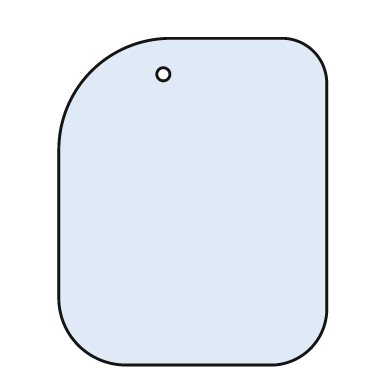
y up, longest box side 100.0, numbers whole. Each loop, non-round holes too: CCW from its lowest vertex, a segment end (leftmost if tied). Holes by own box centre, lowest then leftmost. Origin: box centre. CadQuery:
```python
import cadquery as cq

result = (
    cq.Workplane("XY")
    .moveTo(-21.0, -50.0)
    .lineTo(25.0, -50.0)
    .threePointArc((36.0, -45.0), (41.0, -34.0))
    .lineTo(41.0, 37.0)
    .threePointArc((37.0, 46.0), (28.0, 50.0))
    .lineTo(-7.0, 50.0)
    .threePointArc((-31.0, 40.0), (-41.0, 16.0))
    .lineTo(-41.0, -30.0)
    .threePointArc((-35.0, -44.0), (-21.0, -50.0))
    .close()
    .moveTo(-9.0, 39.0)
    .circle(2.0)
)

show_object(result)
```